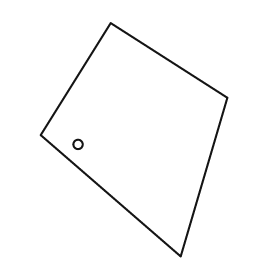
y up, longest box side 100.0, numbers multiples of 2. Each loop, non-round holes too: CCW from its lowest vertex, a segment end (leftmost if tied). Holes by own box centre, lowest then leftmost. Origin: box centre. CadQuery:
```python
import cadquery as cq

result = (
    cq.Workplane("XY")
    .moveTo(20.0, -50.0)
    .lineTo(40.0, 18.0)
    .lineTo(-10.0, 50.0)
    .lineTo(-40.0, 2.0)
    .close()
    .moveTo(-24.0, -2.0)
    .circle(2.0)
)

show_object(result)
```